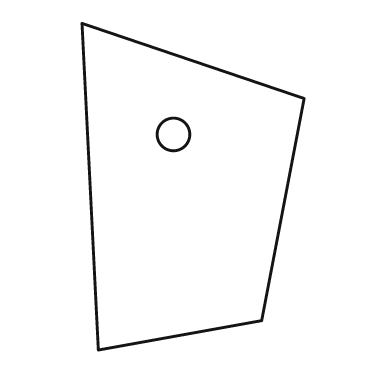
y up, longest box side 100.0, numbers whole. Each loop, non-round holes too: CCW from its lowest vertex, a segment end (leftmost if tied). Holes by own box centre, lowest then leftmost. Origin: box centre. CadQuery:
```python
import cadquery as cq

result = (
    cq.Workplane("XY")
    .moveTo(-29.0, -50.0)
    .lineTo(21.0, -41.0)
    .lineTo(34.0, 27.0)
    .lineTo(-34.0, 50.0)
    .close()
    .moveTo(-6.0, 16.0)
    .circle(5.0)
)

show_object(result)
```